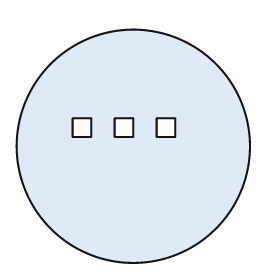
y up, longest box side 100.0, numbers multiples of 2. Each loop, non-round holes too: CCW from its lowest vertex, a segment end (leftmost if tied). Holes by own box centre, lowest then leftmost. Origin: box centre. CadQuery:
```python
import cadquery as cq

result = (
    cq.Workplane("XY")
    .moveTo(0.0, 0.0)
    .circle(50.0)
    .moveTo(-26.0, 4.0)
    .lineTo(-18.0, 4.0)
    .lineTo(-18.0, 12.0)
    .lineTo(-26.0, 12.0)
    .close()
    .moveTo(-8.0, 4.0)
    .lineTo(0.0, 4.0)
    .lineTo(0.0, 12.0)
    .lineTo(-8.0, 12.0)
    .close()
    .moveTo(10.0, 4.0)
    .lineTo(18.0, 4.0)
    .lineTo(18.0, 12.0)
    .lineTo(10.0, 12.0)
    .close()
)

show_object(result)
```